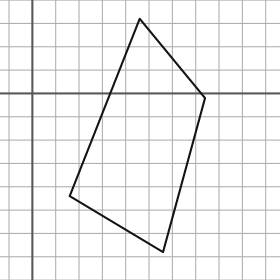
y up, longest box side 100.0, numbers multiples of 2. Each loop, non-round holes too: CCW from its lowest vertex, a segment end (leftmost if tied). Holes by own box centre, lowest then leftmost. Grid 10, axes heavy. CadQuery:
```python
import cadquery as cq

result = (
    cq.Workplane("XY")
    .moveTo(56.0, -68.0)
    .lineTo(74.0, -2.0)
    .lineTo(46.0, 32.0)
    .lineTo(16.0, -44.0)
    .close()
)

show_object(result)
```